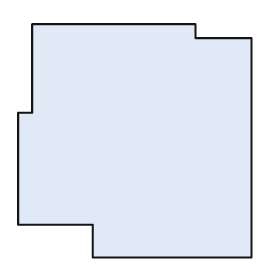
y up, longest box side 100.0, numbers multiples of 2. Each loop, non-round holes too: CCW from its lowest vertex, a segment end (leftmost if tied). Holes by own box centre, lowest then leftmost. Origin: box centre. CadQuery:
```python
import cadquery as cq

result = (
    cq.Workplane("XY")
    .moveTo(-18.0, -50.0)
    .lineTo(50.0, -50.0)
    .lineTo(50.0, 44.0)
    .lineTo(26.0, 44.0)
    .lineTo(26.0, 50.0)
    .lineTo(-44.0, 50.0)
    .lineTo(-44.0, 12.0)
    .lineTo(-50.0, 12.0)
    .lineTo(-50.0, -36.0)
    .lineTo(-18.0, -36.0)
    .close()
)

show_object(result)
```